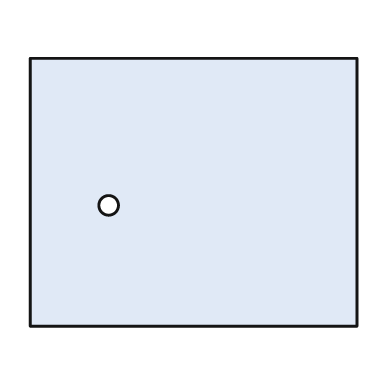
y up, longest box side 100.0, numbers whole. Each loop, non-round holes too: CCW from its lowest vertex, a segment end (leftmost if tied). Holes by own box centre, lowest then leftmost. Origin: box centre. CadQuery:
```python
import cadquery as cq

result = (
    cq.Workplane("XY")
    .moveTo(-50.0, -41.0)
    .lineTo(50.0, -41.0)
    .lineTo(50.0, 41.0)
    .lineTo(-50.0, 41.0)
    .close()
    .moveTo(-26.0, -4.0)
    .circle(3.0)
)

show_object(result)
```